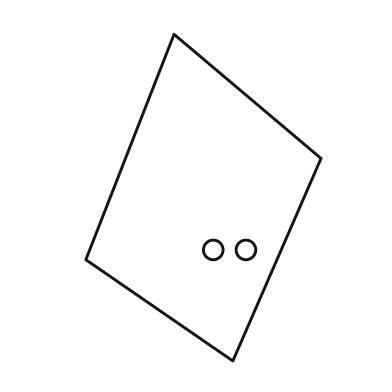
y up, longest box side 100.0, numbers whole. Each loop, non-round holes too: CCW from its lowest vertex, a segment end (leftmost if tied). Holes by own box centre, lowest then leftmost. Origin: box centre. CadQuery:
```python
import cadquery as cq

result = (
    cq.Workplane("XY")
    .moveTo(9.0, -50.0)
    .lineTo(36.0, 12.0)
    .lineTo(-9.0, 50.0)
    .lineTo(-36.0, -19.0)
    .close()
    .moveTo(3.0, -16.0)
    .circle(3.0)
    .moveTo(13.0, -16.0)
    .circle(3.0)
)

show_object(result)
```